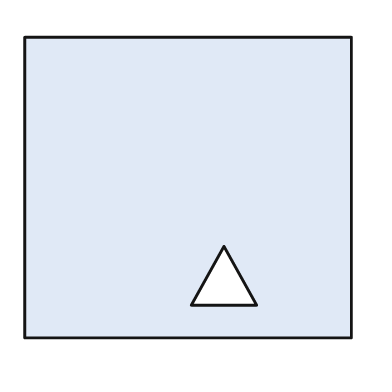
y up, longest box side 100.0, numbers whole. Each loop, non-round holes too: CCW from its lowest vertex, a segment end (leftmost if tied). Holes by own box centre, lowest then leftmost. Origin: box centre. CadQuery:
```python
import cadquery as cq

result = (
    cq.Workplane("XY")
    .moveTo(-50.0, -46.0)
    .lineTo(50.0, -46.0)
    .lineTo(50.0, 46.0)
    .lineTo(-50.0, 46.0)
    .close()
    .moveTo(1.0, -36.0)
    .lineTo(21.0, -36.0)
    .lineTo(11.0, -18.0)
    .close()
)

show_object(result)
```